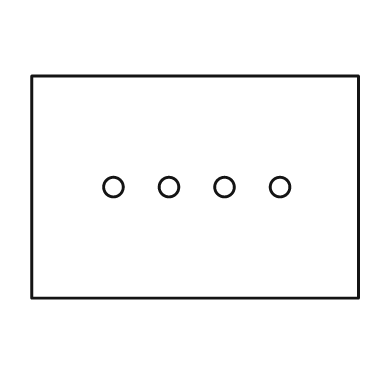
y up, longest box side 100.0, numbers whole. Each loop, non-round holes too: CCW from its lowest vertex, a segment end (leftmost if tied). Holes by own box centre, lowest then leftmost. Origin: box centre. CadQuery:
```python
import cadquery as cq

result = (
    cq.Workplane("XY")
    .moveTo(-50.0, -34.0)
    .lineTo(50.0, -34.0)
    .lineTo(50.0, 34.0)
    .lineTo(-50.0, 34.0)
    .close()
    .moveTo(-25.0, 0.0)
    .circle(3.0)
    .moveTo(-8.0, 0.0)
    .circle(3.0)
    .moveTo(9.0, 0.0)
    .circle(3.0)
    .moveTo(26.0, 0.0)
    .circle(3.0)
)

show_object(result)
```